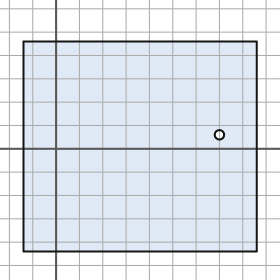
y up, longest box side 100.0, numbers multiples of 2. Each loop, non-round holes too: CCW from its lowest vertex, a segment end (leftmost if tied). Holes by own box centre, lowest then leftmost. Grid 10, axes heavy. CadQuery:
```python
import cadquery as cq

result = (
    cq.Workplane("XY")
    .moveTo(-14.0, -44.0)
    .lineTo(86.0, -44.0)
    .lineTo(86.0, 46.0)
    .lineTo(-14.0, 46.0)
    .close()
    .moveTo(70.0, 6.0)
    .circle(2.0)
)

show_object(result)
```